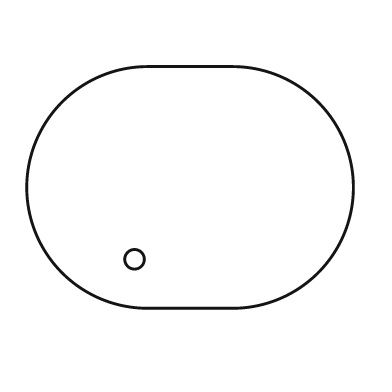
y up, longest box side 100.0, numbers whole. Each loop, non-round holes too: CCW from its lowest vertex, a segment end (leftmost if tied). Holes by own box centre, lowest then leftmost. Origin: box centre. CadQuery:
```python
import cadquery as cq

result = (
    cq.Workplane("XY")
    .moveTo(-13.0, -37.0)
    .lineTo(13.0, -37.0)
    .threePointArc((50.0, 0.0), (13.0, 37.0))
    .lineTo(-13.0, 37.0)
    .threePointArc((-50.0, 0.0), (-13.0, -37.0))
    .close()
    .moveTo(-17.0, -22.0)
    .circle(3.0)
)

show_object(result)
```